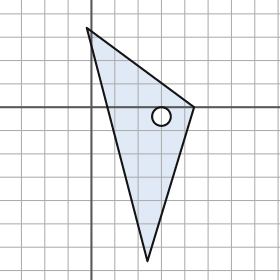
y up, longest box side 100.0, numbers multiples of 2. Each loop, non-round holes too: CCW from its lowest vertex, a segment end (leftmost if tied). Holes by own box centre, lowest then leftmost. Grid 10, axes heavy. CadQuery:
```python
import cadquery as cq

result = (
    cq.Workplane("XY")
    .moveTo(24.0, -66.0)
    .lineTo(44.0, 0.0)
    .lineTo(-2.0, 34.0)
    .close()
    .moveTo(30.0, -4.0)
    .circle(4.0)
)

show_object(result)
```